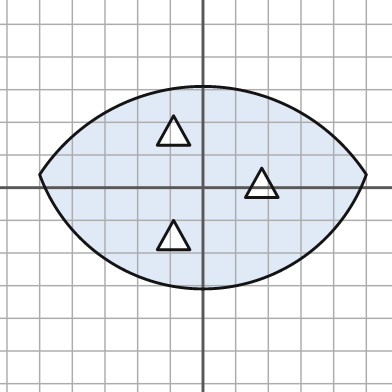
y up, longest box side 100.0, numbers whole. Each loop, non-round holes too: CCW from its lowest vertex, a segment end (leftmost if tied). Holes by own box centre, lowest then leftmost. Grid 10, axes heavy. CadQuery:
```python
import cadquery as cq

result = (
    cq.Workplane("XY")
    .moveTo(-50.0, 4.0)
    .threePointArc((0.0, -31.0), (50.0, 4.0))
    .threePointArc((0.0, 31.0), (-50.0, 4.0))
    .close()
    .moveTo(-14.0, -19.0)
    .lineTo(-4.0, -19.0)
    .lineTo(-9.0, -10.0)
    .close()
    .moveTo(13.0, -3.0)
    .lineTo(23.0, -3.0)
    .lineTo(18.0, 6.0)
    .close()
    .moveTo(-14.0, 13.0)
    .lineTo(-4.0, 13.0)
    .lineTo(-9.0, 22.0)
    .close()
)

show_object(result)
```